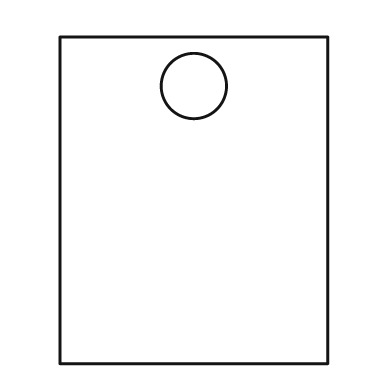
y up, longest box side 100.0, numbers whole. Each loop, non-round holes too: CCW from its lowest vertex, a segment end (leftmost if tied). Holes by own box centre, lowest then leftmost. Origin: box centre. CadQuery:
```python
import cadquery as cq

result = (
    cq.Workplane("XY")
    .moveTo(-41.0, -50.0)
    .lineTo(41.0, -50.0)
    .lineTo(41.0, 50.0)
    .lineTo(-41.0, 50.0)
    .close()
    .moveTo(0.0, 35.0)
    .circle(10.0)
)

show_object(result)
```